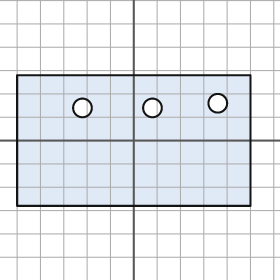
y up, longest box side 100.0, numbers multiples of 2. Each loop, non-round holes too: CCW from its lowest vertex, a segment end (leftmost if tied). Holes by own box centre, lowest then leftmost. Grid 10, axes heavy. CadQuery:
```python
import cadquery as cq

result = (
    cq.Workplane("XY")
    .moveTo(-50.0, -28.0)
    .lineTo(50.0, -28.0)
    .lineTo(50.0, 28.0)
    .lineTo(-50.0, 28.0)
    .close()
    .moveTo(-22.0, 14.0)
    .circle(4.0)
    .moveTo(8.0, 14.0)
    .circle(4.0)
    .moveTo(36.0, 16.0)
    .circle(4.0)
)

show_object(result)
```